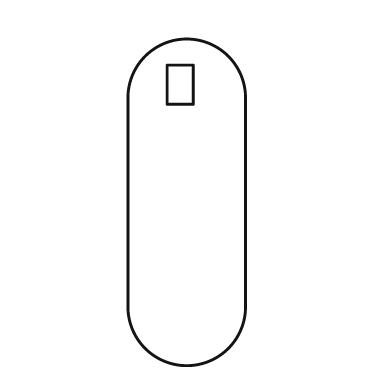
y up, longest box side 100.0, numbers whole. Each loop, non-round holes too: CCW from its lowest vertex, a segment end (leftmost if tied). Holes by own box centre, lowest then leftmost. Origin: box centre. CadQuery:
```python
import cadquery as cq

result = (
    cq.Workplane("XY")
    .moveTo(-18.0, -32.0)
    .threePointArc((0.0, -50.0), (18.0, -32.0))
    .lineTo(18.0, 32.0)
    .threePointArc((0.0, 50.0), (-18.0, 32.0))
    .close()
    .moveTo(-6.0, 30.0)
    .lineTo(2.0, 30.0)
    .lineTo(2.0, 42.0)
    .lineTo(-6.0, 42.0)
    .close()
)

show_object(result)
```